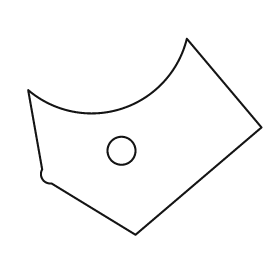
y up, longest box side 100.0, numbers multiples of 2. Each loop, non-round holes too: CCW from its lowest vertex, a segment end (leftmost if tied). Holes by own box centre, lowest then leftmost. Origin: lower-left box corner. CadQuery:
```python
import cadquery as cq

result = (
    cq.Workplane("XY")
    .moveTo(46.0, 0.0)
    .lineTo(100.0, 46.0)
    .lineTo(68.0, 84.0)
    .threePointArc((40.0, 54.0), (0.0, 62.0))
    .lineTo(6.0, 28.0)
    .threePointArc((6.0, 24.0), (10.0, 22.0))
    .close()
    .moveTo(40.0, 36.0)
    .circle(6.0)
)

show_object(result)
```